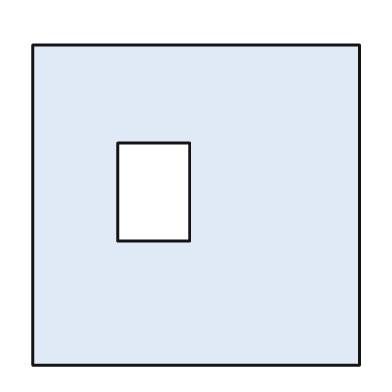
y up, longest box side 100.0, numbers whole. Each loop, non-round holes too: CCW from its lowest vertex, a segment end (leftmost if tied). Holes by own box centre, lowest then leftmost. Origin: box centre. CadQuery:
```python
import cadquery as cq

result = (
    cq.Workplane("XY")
    .moveTo(-50.0, -49.0)
    .lineTo(50.0, -49.0)
    .lineTo(50.0, 49.0)
    .lineTo(-50.0, 49.0)
    .close()
    .moveTo(-24.0, -11.0)
    .lineTo(-2.0, -11.0)
    .lineTo(-2.0, 19.0)
    .lineTo(-24.0, 19.0)
    .close()
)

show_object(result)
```